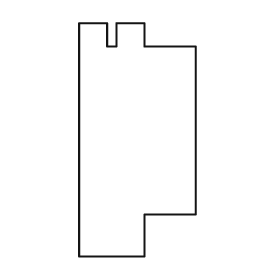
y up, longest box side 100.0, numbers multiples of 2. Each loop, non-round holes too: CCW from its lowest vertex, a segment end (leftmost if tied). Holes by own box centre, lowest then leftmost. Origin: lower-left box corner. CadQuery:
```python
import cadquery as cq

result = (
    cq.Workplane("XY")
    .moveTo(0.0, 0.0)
    .lineTo(28.0, 0.0)
    .lineTo(28.0, 18.0)
    .lineTo(50.0, 18.0)
    .lineTo(50.0, 90.0)
    .lineTo(28.0, 90.0)
    .lineTo(28.0, 100.0)
    .lineTo(16.0, 100.0)
    .lineTo(16.0, 90.0)
    .lineTo(12.0, 90.0)
    .lineTo(12.0, 100.0)
    .lineTo(0.0, 100.0)
    .close()
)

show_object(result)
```